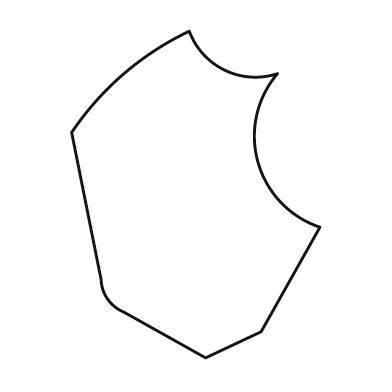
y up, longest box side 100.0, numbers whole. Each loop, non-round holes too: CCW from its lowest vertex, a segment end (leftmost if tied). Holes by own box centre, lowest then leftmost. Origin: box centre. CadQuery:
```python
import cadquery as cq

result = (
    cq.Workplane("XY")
    .moveTo(3.0, -50.0)
    .lineTo(20.0, -42.0)
    .lineTo(38.0, -10.0)
    .threePointArc((19.0, 10.0), (25.0, 37.0))
    .threePointArc((9.0, 38.0), (-2.0, 50.0))
    .threePointArc((-22.0, 37.0), (-38.0, 19.0))
    .lineTo(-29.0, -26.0)
    .threePointArc((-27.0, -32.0), (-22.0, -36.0))
    .close()
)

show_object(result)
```